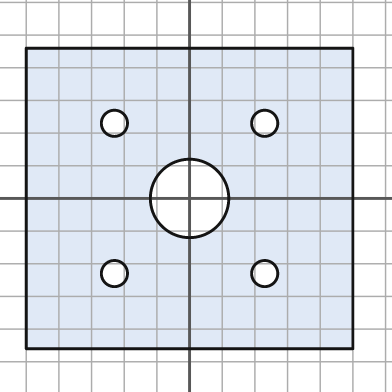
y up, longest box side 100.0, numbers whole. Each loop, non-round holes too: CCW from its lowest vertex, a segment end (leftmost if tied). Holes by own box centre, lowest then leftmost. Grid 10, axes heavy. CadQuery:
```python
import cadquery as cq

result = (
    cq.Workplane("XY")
    .moveTo(-50.0, -46.0)
    .lineTo(50.0, -46.0)
    .lineTo(50.0, 46.0)
    .lineTo(-50.0, 46.0)
    .close()
    .moveTo(-23.0, -23.0)
    .circle(4.0)
    .moveTo(23.0, -23.0)
    .circle(4.0)
    .moveTo(0.0, 0.0)
    .circle(12.0)
    .moveTo(-23.0, 23.0)
    .circle(4.0)
    .moveTo(23.0, 23.0)
    .circle(4.0)
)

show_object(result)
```